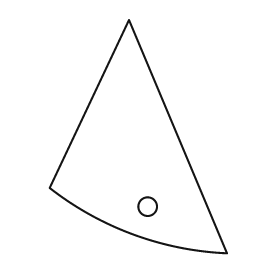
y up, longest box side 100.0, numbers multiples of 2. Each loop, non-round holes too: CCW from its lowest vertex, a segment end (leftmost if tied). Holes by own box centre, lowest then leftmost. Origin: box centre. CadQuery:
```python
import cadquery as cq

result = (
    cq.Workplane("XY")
    .moveTo(38.0, -50.0)
    .lineTo(-4.0, 50.0)
    .lineTo(-38.0, -22.0)
    .threePointArc((-2.0, -42.0), (38.0, -50.0))
    .close()
    .moveTo(4.0, -30.0)
    .circle(4.0)
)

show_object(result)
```